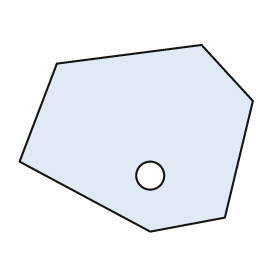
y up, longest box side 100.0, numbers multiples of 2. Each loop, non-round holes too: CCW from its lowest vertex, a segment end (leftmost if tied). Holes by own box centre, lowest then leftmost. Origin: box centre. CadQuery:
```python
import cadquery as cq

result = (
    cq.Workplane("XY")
    .moveTo(6.0, -40.0)
    .lineTo(38.0, -34.0)
    .lineTo(50.0, 16.0)
    .lineTo(28.0, 40.0)
    .lineTo(-34.0, 32.0)
    .lineTo(-50.0, -10.0)
    .close()
    .moveTo(6.0, -16.0)
    .circle(6.0)
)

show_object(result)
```